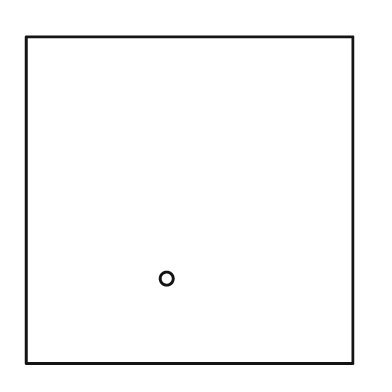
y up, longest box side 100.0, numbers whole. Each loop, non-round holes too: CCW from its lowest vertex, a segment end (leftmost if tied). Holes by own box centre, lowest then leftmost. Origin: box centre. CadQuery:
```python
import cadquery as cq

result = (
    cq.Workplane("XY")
    .moveTo(-50.0, -50.0)
    .lineTo(50.0, -50.0)
    .lineTo(50.0, 50.0)
    .lineTo(-50.0, 50.0)
    .close()
    .moveTo(-7.0, -24.0)
    .circle(2.0)
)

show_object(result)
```